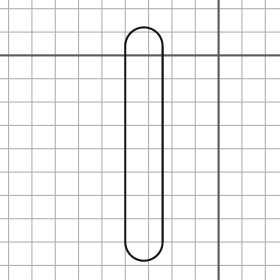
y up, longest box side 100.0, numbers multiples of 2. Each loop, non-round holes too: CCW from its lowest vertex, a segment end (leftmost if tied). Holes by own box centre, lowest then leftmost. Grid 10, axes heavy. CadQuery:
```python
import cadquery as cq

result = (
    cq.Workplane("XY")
    .moveTo(-40.0, -80.0)
    .threePointArc((-32.0, -88.0), (-24.0, -80.0))
    .lineTo(-24.0, 4.0)
    .threePointArc((-32.0, 12.0), (-40.0, 4.0))
    .close()
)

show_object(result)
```